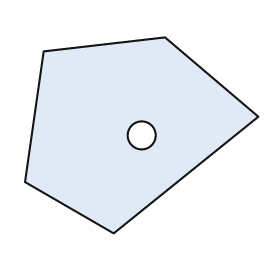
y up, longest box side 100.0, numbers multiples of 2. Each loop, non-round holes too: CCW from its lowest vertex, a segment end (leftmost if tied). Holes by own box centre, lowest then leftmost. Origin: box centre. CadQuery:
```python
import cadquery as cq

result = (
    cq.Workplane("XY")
    .moveTo(-12.0, -42.0)
    .lineTo(50.0, 8.0)
    .lineTo(10.0, 42.0)
    .lineTo(-42.0, 36.0)
    .lineTo(-50.0, -20.0)
    .close()
    .moveTo(0.0, 0.0)
    .circle(6.0)
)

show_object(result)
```